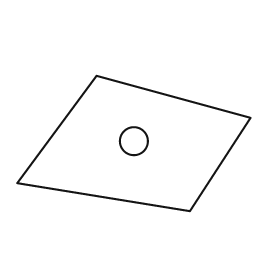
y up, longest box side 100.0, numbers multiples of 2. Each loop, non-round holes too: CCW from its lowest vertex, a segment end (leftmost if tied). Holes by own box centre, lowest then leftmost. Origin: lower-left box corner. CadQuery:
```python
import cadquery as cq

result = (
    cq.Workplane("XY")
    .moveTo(74.0, 0.0)
    .lineTo(100.0, 40.0)
    .lineTo(34.0, 58.0)
    .lineTo(0.0, 12.0)
    .close()
    .moveTo(50.0, 30.0)
    .circle(6.0)
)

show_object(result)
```